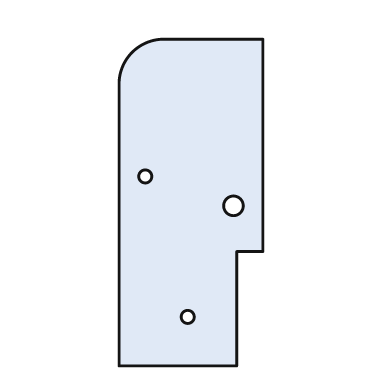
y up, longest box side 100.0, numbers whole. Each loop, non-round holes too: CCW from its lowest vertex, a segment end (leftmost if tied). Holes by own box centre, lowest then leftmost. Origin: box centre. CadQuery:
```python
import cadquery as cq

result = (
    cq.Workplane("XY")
    .moveTo(-22.0, -50.0)
    .lineTo(14.0, -50.0)
    .lineTo(14.0, -15.0)
    .lineTo(22.0, -15.0)
    .lineTo(22.0, 50.0)
    .lineTo(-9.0, 50.0)
    .threePointArc((-18.0, 46.0), (-22.0, 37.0))
    .close()
    .moveTo(-1.0, -35.0)
    .circle(2.0)
    .moveTo(13.0, -1.0)
    .circle(3.0)
    .moveTo(-14.0, 8.0)
    .circle(2.0)
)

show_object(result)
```